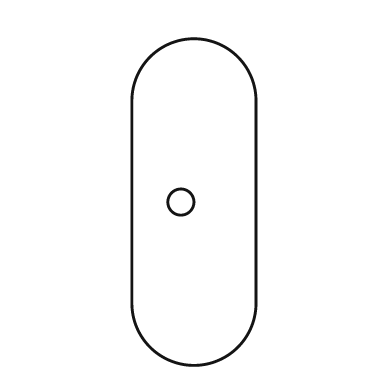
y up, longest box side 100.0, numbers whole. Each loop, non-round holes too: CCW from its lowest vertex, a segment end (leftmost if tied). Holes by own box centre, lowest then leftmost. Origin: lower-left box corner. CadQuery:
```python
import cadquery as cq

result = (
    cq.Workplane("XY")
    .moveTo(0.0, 19.0)
    .threePointArc((19.0, 0.0), (38.0, 19.0))
    .lineTo(38.0, 81.0)
    .threePointArc((19.0, 100.0), (0.0, 81.0))
    .close()
    .moveTo(15.0, 50.0)
    .circle(4.0)
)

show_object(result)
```